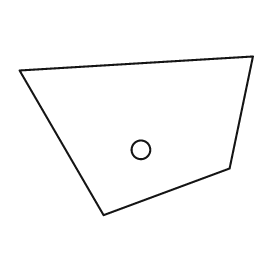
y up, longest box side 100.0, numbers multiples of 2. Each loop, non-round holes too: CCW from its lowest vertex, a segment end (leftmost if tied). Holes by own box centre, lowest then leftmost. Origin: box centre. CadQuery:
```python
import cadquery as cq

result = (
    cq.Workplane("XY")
    .moveTo(-14.0, -34.0)
    .lineTo(40.0, -14.0)
    .lineTo(50.0, 34.0)
    .lineTo(-50.0, 28.0)
    .close()
    .moveTo(2.0, -6.0)
    .circle(4.0)
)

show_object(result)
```